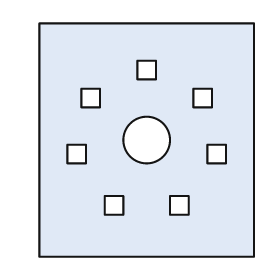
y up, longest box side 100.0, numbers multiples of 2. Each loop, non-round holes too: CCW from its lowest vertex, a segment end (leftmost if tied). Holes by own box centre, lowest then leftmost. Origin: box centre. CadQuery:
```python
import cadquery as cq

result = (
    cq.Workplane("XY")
    .moveTo(-46.0, -50.0)
    .lineTo(46.0, -50.0)
    .lineTo(46.0, 50.0)
    .lineTo(-46.0, 50.0)
    .close()
    .moveTo(-18.0, -32.0)
    .lineTo(-10.0, -32.0)
    .lineTo(-10.0, -24.0)
    .lineTo(-18.0, -24.0)
    .close()
    .moveTo(10.0, -32.0)
    .lineTo(18.0, -32.0)
    .lineTo(18.0, -24.0)
    .lineTo(10.0, -24.0)
    .close()
    .moveTo(-34.0, -10.0)
    .lineTo(-26.0, -10.0)
    .lineTo(-26.0, -2.0)
    .lineTo(-34.0, -2.0)
    .close()
    .moveTo(26.0, -10.0)
    .lineTo(34.0, -10.0)
    .lineTo(34.0, -2.0)
    .lineTo(26.0, -2.0)
    .close()
    .moveTo(0.0, 0.0)
    .circle(10.0)
    .moveTo(-28.0, 14.0)
    .lineTo(-20.0, 14.0)
    .lineTo(-20.0, 22.0)
    .lineTo(-28.0, 22.0)
    .close()
    .moveTo(20.0, 14.0)
    .lineTo(28.0, 14.0)
    .lineTo(28.0, 22.0)
    .lineTo(20.0, 22.0)
    .close()
    .moveTo(-4.0, 26.0)
    .lineTo(4.0, 26.0)
    .lineTo(4.0, 34.0)
    .lineTo(-4.0, 34.0)
    .close()
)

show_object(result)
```